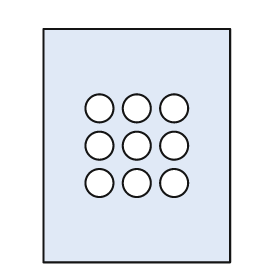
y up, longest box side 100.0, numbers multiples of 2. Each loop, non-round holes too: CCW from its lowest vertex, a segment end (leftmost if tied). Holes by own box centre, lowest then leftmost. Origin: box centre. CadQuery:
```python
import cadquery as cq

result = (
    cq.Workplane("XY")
    .moveTo(-40.0, -50.0)
    .lineTo(40.0, -50.0)
    .lineTo(40.0, 50.0)
    .lineTo(-40.0, 50.0)
    .close()
    .moveTo(-16.0, -16.0)
    .circle(6.0)
    .moveTo(0.0, -16.0)
    .circle(6.0)
    .moveTo(16.0, -16.0)
    .circle(6.0)
    .moveTo(-16.0, 0.0)
    .circle(6.0)
    .moveTo(0.0, 0.0)
    .circle(6.0)
    .moveTo(16.0, 0.0)
    .circle(6.0)
    .moveTo(-16.0, 16.0)
    .circle(6.0)
    .moveTo(0.0, 16.0)
    .circle(6.0)
    .moveTo(16.0, 16.0)
    .circle(6.0)
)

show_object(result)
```